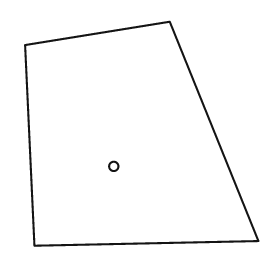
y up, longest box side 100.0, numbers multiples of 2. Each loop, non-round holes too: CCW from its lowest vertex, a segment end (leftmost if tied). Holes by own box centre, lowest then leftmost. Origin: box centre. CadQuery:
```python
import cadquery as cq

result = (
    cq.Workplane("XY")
    .moveTo(-46.0, -48.0)
    .lineTo(50.0, -46.0)
    .lineTo(12.0, 48.0)
    .lineTo(-50.0, 38.0)
    .close()
    .moveTo(-12.0, -14.0)
    .circle(2.0)
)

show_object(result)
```